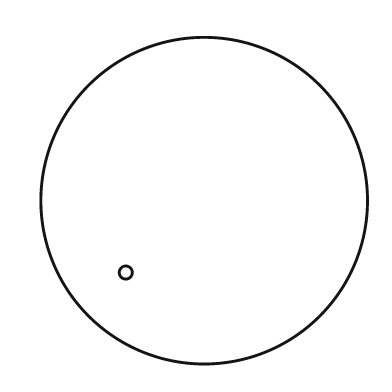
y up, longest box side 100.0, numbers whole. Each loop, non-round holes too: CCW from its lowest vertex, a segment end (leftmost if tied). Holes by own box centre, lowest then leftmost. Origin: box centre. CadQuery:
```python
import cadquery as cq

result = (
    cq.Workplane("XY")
    .moveTo(0.0, 0.0)
    .circle(50.0)
    .moveTo(-24.0, -22.0)
    .circle(2.0)
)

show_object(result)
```